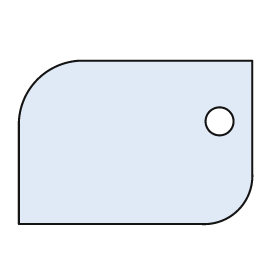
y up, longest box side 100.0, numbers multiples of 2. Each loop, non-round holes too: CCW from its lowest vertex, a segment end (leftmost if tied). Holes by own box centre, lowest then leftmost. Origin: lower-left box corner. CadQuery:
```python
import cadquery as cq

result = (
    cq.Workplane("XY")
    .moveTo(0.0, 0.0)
    .lineTo(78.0, 0.0)
    .threePointArc((94.0, 6.0), (100.0, 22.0))
    .lineTo(100.0, 70.0)
    .lineTo(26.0, 70.0)
    .threePointArc((8.0, 62.0), (0.0, 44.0))
    .close()
    .moveTo(86.0, 44.0)
    .circle(6.0)
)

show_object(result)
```